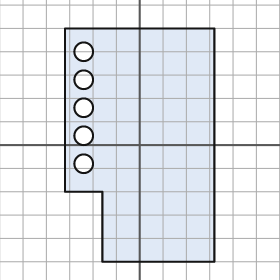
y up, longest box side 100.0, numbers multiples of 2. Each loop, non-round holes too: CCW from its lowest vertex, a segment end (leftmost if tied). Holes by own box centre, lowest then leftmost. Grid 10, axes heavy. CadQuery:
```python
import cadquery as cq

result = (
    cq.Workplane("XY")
    .moveTo(-16.0, -50.0)
    .lineTo(32.0, -50.0)
    .lineTo(32.0, 50.0)
    .lineTo(-32.0, 50.0)
    .lineTo(-32.0, -20.0)
    .lineTo(-16.0, -20.0)
    .close()
    .moveTo(-24.0, -8.0)
    .circle(4.0)
    .moveTo(-24.0, 4.0)
    .circle(4.0)
    .moveTo(-24.0, 16.0)
    .circle(4.0)
    .moveTo(-24.0, 28.0)
    .circle(4.0)
    .moveTo(-24.0, 40.0)
    .circle(4.0)
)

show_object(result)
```